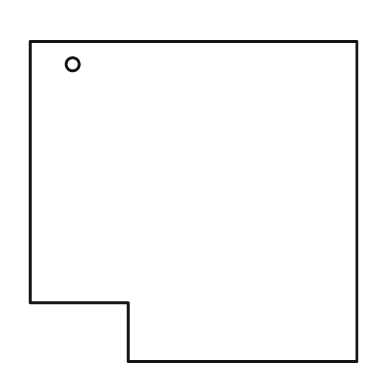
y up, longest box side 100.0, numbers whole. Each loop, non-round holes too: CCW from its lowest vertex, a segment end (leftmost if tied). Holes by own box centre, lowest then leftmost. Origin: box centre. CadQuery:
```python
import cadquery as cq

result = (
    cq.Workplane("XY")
    .moveTo(-20.0, -49.0)
    .lineTo(50.0, -49.0)
    .lineTo(50.0, 49.0)
    .lineTo(-50.0, 49.0)
    .lineTo(-50.0, -31.0)
    .lineTo(-20.0, -31.0)
    .close()
    .moveTo(-37.0, 42.0)
    .circle(2.0)
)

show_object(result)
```